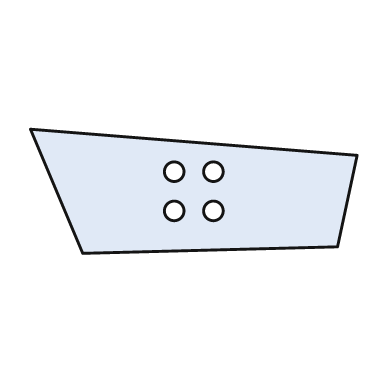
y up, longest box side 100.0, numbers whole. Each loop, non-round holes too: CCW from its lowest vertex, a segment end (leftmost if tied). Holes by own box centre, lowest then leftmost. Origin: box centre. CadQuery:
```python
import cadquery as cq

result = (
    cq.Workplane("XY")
    .moveTo(-34.0, -19.0)
    .lineTo(44.0, -17.0)
    .lineTo(50.0, 11.0)
    .lineTo(-50.0, 19.0)
    .close()
    .moveTo(-6.0, -6.0)
    .circle(3.0)
    .moveTo(6.0, -6.0)
    .circle(3.0)
    .moveTo(-6.0, 6.0)
    .circle(3.0)
    .moveTo(6.0, 6.0)
    .circle(3.0)
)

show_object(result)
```